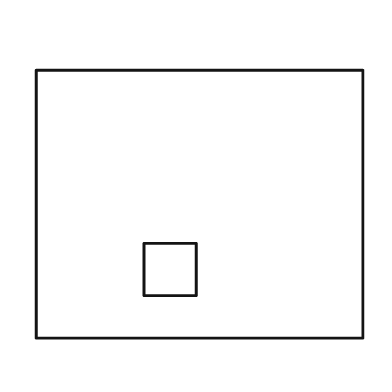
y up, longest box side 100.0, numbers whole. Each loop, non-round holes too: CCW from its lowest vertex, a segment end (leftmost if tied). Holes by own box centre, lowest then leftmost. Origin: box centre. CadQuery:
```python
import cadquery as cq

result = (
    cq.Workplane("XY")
    .moveTo(-50.0, -41.0)
    .lineTo(50.0, -41.0)
    .lineTo(50.0, 41.0)
    .lineTo(-50.0, 41.0)
    .close()
    .moveTo(-17.0, -28.0)
    .lineTo(-1.0, -28.0)
    .lineTo(-1.0, -12.0)
    .lineTo(-17.0, -12.0)
    .close()
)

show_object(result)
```